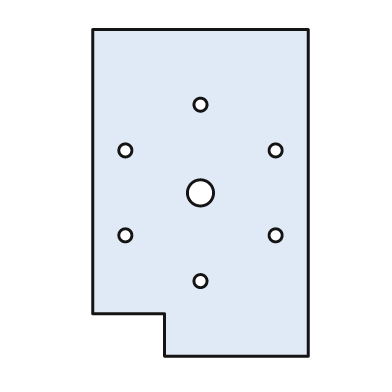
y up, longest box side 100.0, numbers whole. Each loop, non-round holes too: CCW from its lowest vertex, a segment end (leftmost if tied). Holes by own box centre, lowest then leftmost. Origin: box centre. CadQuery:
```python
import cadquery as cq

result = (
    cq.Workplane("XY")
    .moveTo(-11.0, -50.0)
    .lineTo(33.0, -50.0)
    .lineTo(33.0, 50.0)
    .lineTo(-33.0, 50.0)
    .lineTo(-33.0, -37.0)
    .lineTo(-11.0, -37.0)
    .close()
    .moveTo(0.0, -27.0)
    .circle(2.0)
    .moveTo(-23.0, -13.0)
    .circle(2.0)
    .moveTo(23.0, -13.0)
    .circle(2.0)
    .moveTo(0.0, 0.0)
    .circle(4.0)
    .moveTo(-23.0, 13.0)
    .circle(2.0)
    .moveTo(23.0, 13.0)
    .circle(2.0)
    .moveTo(0.0, 27.0)
    .circle(2.0)
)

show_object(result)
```